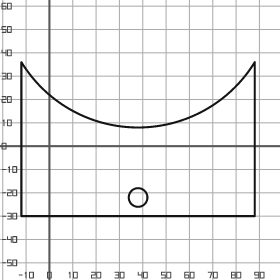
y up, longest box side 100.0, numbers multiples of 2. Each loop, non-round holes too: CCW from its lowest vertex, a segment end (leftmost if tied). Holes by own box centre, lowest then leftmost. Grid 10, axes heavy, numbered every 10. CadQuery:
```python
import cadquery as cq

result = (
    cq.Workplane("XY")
    .moveTo(-12.0, -30.0)
    .lineTo(88.0, -30.0)
    .lineTo(88.0, 36.0)
    .threePointArc((38.0, 8.0), (-12.0, 36.0))
    .close()
    .moveTo(38.0, -22.0)
    .circle(4.0)
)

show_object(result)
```